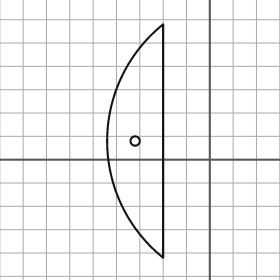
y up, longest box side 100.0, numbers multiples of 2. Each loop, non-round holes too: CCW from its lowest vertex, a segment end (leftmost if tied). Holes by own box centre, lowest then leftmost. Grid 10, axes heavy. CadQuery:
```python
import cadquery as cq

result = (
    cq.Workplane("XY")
    .moveTo(-20.0, -42.0)
    .lineTo(-20.0, 58.0)
    .threePointArc((-44.0, 8.0), (-20.0, -42.0))
    .close()
    .moveTo(-32.0, 8.0)
    .circle(2.0)
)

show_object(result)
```